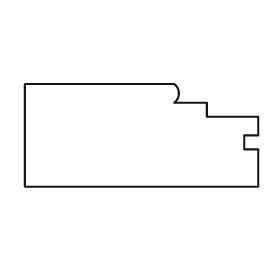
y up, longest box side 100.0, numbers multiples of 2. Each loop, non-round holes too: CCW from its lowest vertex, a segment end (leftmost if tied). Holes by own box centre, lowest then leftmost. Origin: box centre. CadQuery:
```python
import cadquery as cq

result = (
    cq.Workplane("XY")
    .moveTo(-50.0, -22.0)
    .lineTo(50.0, -22.0)
    .lineTo(50.0, -6.0)
    .lineTo(44.0, -6.0)
    .lineTo(44.0, 0.0)
    .lineTo(50.0, 0.0)
    .lineTo(50.0, 8.0)
    .lineTo(28.0, 8.0)
    .lineTo(28.0, 14.0)
    .lineTo(14.0, 14.0)
    .threePointArc((16.0, 18.0), (14.0, 22.0))
    .lineTo(-50.0, 22.0)
    .close()
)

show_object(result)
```